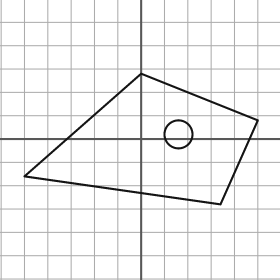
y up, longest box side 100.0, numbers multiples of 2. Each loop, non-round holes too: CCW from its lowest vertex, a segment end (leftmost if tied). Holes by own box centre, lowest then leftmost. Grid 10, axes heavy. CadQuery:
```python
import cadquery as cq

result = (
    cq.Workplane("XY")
    .moveTo(34.0, -28.0)
    .lineTo(50.0, 8.0)
    .lineTo(0.0, 28.0)
    .lineTo(-50.0, -16.0)
    .close()
    .moveTo(16.0, 2.0)
    .circle(6.0)
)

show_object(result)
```